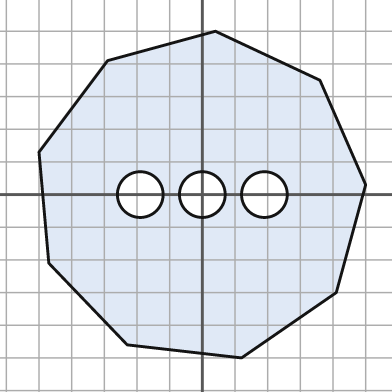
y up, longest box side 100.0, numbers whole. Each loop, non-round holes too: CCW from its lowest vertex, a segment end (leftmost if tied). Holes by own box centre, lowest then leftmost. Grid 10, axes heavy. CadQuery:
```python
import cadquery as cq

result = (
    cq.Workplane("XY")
    .moveTo(12.0, -50.0)
    .lineTo(41.0, -30.0)
    .lineTo(50.0, 3.0)
    .lineTo(36.0, 35.0)
    .lineTo(4.0, 50.0)
    .lineTo(-29.0, 41.0)
    .lineTo(-50.0, 13.0)
    .lineTo(-47.0, -21.0)
    .lineTo(-23.0, -46.0)
    .close()
    .moveTo(-19.0, 0.0)
    .circle(7.0)
    .moveTo(0.0, 0.0)
    .circle(7.0)
    .moveTo(19.0, 0.0)
    .circle(7.0)
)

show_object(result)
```